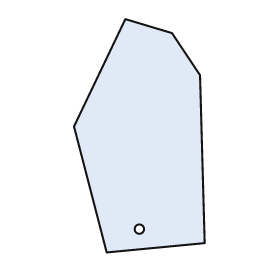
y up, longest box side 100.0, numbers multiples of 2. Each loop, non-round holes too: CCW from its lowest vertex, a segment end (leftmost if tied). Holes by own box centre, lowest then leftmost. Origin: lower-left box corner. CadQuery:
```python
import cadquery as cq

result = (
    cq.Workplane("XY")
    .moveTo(14.0, 0.0)
    .lineTo(56.0, 4.0)
    .lineTo(54.0, 76.0)
    .lineTo(42.0, 94.0)
    .lineTo(22.0, 100.0)
    .lineTo(0.0, 54.0)
    .close()
    .moveTo(28.0, 10.0)
    .circle(2.0)
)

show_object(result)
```